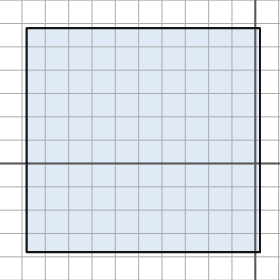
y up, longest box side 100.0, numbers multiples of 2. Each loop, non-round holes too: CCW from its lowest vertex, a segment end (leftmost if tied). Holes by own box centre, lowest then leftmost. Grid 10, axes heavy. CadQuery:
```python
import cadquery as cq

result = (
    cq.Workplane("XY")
    .moveTo(-98.0, -38.0)
    .lineTo(2.0, -38.0)
    .lineTo(2.0, 58.0)
    .lineTo(-98.0, 58.0)
    .close()
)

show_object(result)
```